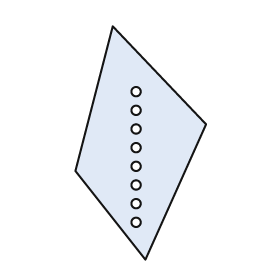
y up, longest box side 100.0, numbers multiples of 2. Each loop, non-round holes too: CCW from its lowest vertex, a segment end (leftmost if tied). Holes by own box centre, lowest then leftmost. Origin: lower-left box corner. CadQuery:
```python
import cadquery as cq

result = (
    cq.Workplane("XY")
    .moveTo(30.0, 0.0)
    .lineTo(56.0, 58.0)
    .lineTo(16.0, 100.0)
    .lineTo(0.0, 38.0)
    .close()
    .moveTo(26.0, 16.0)
    .circle(2.0)
    .moveTo(26.0, 24.0)
    .circle(2.0)
    .moveTo(26.0, 32.0)
    .circle(2.0)
    .moveTo(26.0, 40.0)
    .circle(2.0)
    .moveTo(26.0, 48.0)
    .circle(2.0)
    .moveTo(26.0, 56.0)
    .circle(2.0)
    .moveTo(26.0, 64.0)
    .circle(2.0)
    .moveTo(26.0, 72.0)
    .circle(2.0)
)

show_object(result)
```